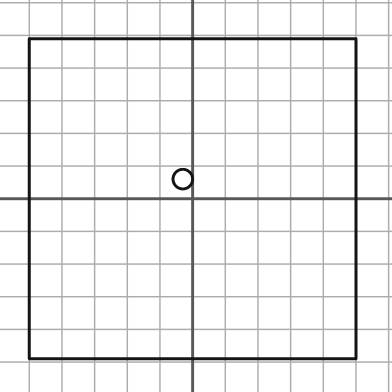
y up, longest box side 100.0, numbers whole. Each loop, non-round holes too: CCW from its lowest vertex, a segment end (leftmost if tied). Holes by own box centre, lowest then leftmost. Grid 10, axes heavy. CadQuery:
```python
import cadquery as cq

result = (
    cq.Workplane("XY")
    .moveTo(-50.0, -49.0)
    .lineTo(50.0, -49.0)
    .lineTo(50.0, 49.0)
    .lineTo(-50.0, 49.0)
    .close()
    .moveTo(-3.0, 6.0)
    .circle(3.0)
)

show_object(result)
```